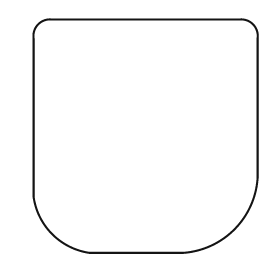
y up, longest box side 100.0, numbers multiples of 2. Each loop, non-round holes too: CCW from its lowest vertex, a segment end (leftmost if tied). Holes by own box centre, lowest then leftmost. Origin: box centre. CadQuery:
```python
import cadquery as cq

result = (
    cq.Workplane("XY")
    .moveTo(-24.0, -50.0)
    .lineTo(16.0, -50.0)
    .threePointArc((38.0, -40.0), (48.0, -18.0))
    .lineTo(48.0, 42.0)
    .threePointArc((46.0, 48.0), (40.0, 50.0))
    .lineTo(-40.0, 50.0)
    .threePointArc((-46.0, 48.0), (-48.0, 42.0))
    .lineTo(-48.0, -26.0)
    .threePointArc((-40.0, -42.0), (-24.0, -50.0))
    .close()
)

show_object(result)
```